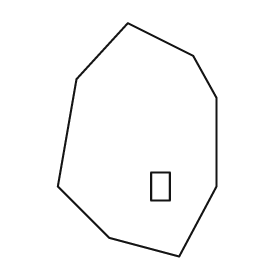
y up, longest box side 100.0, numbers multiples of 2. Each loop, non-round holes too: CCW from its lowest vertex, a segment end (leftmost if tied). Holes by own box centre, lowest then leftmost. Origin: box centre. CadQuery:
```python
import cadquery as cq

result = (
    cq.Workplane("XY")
    .moveTo(18.0, -50.0)
    .lineTo(34.0, -20.0)
    .lineTo(34.0, 18.0)
    .lineTo(24.0, 36.0)
    .lineTo(-4.0, 50.0)
    .lineTo(-26.0, 26.0)
    .lineTo(-34.0, -20.0)
    .lineTo(-12.0, -42.0)
    .close()
    .moveTo(6.0, -26.0)
    .lineTo(14.0, -26.0)
    .lineTo(14.0, -14.0)
    .lineTo(6.0, -14.0)
    .close()
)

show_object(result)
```